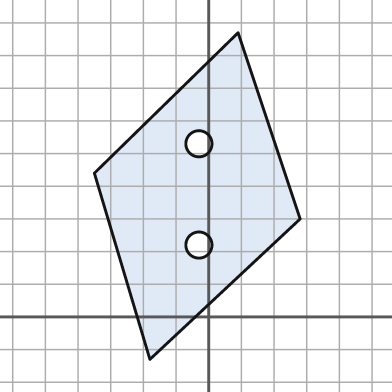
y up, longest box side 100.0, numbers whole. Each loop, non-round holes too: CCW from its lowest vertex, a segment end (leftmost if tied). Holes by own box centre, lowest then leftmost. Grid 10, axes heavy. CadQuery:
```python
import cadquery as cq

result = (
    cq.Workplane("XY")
    .moveTo(-18.0, -13.0)
    .lineTo(28.0, 30.0)
    .lineTo(9.0, 87.0)
    .lineTo(-35.0, 44.0)
    .close()
    .moveTo(-3.0, 22.0)
    .circle(4.0)
    .moveTo(-3.0, 53.0)
    .circle(4.0)
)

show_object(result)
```